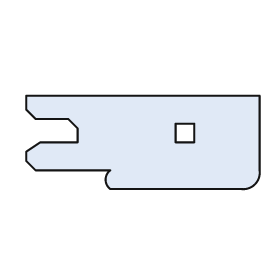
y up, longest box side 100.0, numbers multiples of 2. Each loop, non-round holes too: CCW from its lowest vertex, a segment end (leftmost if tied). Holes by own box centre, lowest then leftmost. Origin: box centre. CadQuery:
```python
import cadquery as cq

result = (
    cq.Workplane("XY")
    .moveTo(-14.0, -20.0)
    .lineTo(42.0, -20.0)
    .threePointArc((48.0, -18.0), (50.0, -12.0))
    .lineTo(50.0, 20.0)
    .lineTo(-50.0, 20.0)
    .lineTo(-50.0, 14.0)
    .lineTo(-46.0, 10.0)
    .lineTo(-32.0, 10.0)
    .lineTo(-28.0, 6.0)
    .lineTo(-28.0, 0.0)
    .lineTo(-44.0, 0.0)
    .lineTo(-50.0, -4.0)
    .lineTo(-50.0, -8.0)
    .lineTo(-46.0, -12.0)
    .lineTo(-14.0, -12.0)
    .threePointArc((-16.0, -16.0), (-14.0, -20.0))
    .close()
    .moveTo(14.0, 0.0)
    .lineTo(22.0, 0.0)
    .lineTo(22.0, 8.0)
    .lineTo(14.0, 8.0)
    .close()
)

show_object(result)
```